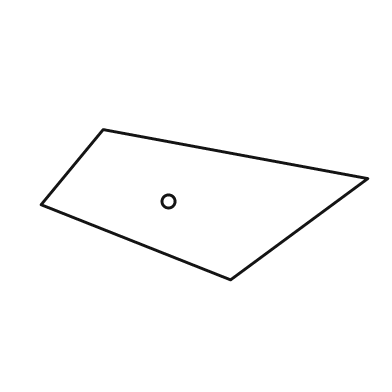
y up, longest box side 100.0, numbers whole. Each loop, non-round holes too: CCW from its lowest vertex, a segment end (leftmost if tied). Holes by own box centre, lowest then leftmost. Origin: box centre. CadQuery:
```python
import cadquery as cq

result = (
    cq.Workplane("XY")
    .moveTo(8.0, -23.0)
    .lineTo(50.0, 8.0)
    .lineTo(-31.0, 23.0)
    .lineTo(-50.0, 0.0)
    .close()
    .moveTo(-11.0, 1.0)
    .circle(2.0)
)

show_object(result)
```